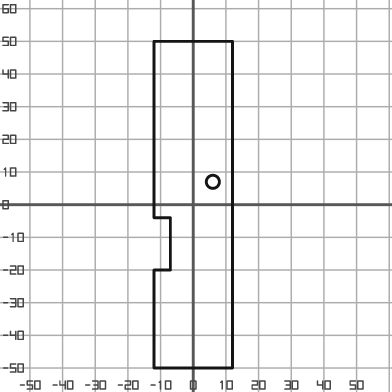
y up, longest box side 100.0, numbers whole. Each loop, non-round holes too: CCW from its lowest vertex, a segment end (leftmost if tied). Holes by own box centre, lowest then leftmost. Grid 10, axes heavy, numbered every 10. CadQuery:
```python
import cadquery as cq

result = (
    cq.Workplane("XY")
    .moveTo(-12.0, -50.0)
    .lineTo(12.0, -50.0)
    .lineTo(12.0, 50.0)
    .lineTo(-12.0, 50.0)
    .lineTo(-12.0, -4.0)
    .lineTo(-7.0, -4.0)
    .lineTo(-7.0, -20.0)
    .lineTo(-12.0, -20.0)
    .close()
    .moveTo(6.0, 7.0)
    .circle(2.0)
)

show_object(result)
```